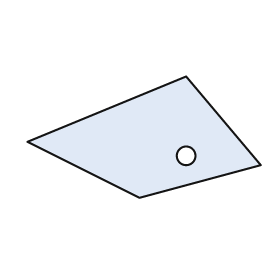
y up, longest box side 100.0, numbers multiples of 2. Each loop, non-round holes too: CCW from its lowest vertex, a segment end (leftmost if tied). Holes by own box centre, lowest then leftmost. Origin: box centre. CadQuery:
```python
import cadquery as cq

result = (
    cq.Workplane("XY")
    .moveTo(-2.0, -26.0)
    .lineTo(50.0, -12.0)
    .lineTo(18.0, 26.0)
    .lineTo(-50.0, -2.0)
    .close()
    .moveTo(18.0, -8.0)
    .circle(4.0)
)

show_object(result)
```